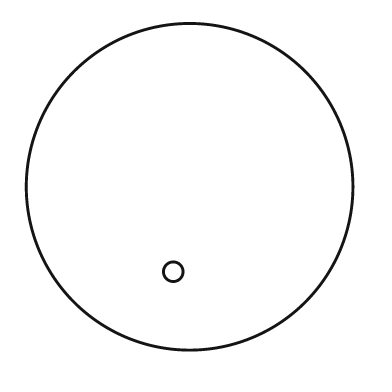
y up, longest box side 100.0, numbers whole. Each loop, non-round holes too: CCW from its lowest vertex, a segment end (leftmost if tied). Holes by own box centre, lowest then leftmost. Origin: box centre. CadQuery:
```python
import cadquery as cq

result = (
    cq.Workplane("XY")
    .moveTo(0.0, 0.0)
    .circle(50.0)
    .moveTo(-5.0, -26.0)
    .circle(3.0)
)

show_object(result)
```